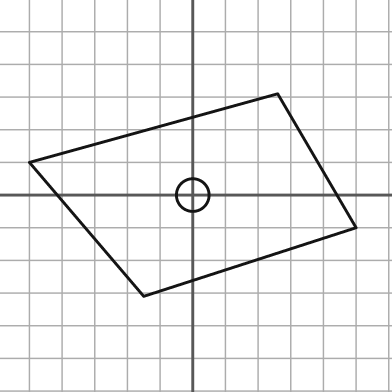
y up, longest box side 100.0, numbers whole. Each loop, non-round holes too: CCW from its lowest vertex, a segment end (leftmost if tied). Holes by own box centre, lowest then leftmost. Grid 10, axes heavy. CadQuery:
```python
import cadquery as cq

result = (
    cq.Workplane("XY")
    .moveTo(-15.0, -31.0)
    .lineTo(50.0, -10.0)
    .lineTo(26.0, 31.0)
    .lineTo(-50.0, 10.0)
    .close()
    .moveTo(0.0, 0.0)
    .circle(5.0)
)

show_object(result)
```